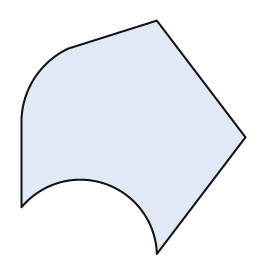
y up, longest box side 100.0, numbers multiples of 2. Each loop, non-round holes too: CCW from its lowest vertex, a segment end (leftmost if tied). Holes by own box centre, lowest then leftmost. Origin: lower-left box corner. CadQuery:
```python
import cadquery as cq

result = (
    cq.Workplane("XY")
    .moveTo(58.0, 0.0)
    .lineTo(96.0, 50.0)
    .lineTo(58.0, 100.0)
    .lineTo(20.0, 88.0)
    .threePointArc((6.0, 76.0), (0.0, 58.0))
    .lineTo(0.0, 20.0)
    .threePointArc((36.0, 30.0), (58.0, 0.0))
    .close()
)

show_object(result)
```